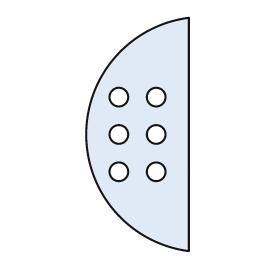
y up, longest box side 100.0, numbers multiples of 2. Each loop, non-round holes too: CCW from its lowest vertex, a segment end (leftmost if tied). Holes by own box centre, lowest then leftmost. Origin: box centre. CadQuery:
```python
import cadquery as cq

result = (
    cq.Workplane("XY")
    .moveTo(22.0, -50.0)
    .lineTo(22.0, 50.0)
    .threePointArc((-22.0, 0.0), (22.0, -50.0))
    .close()
    .moveTo(-8.0, -16.0)
    .circle(4.0)
    .moveTo(8.0, -16.0)
    .circle(4.0)
    .moveTo(-8.0, 0.0)
    .circle(4.0)
    .moveTo(8.0, 0.0)
    .circle(4.0)
    .moveTo(-8.0, 16.0)
    .circle(4.0)
    .moveTo(8.0, 16.0)
    .circle(4.0)
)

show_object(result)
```